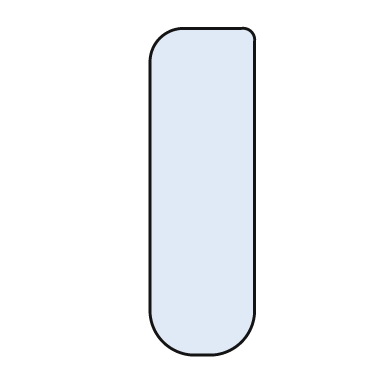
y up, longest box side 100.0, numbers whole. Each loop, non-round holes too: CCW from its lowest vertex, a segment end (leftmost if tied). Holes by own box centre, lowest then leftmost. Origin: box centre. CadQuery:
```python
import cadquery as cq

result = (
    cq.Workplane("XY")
    .moveTo(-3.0, -50.0)
    .lineTo(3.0, -50.0)
    .threePointArc((12.0, -46.0), (16.0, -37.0))
    .lineTo(16.0, 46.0)
    .threePointArc((15.0, 49.0), (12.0, 50.0))
    .lineTo(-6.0, 50.0)
    .threePointArc((-13.0, 47.0), (-16.0, 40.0))
    .lineTo(-16.0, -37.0)
    .threePointArc((-12.0, -46.0), (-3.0, -50.0))
    .close()
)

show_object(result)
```